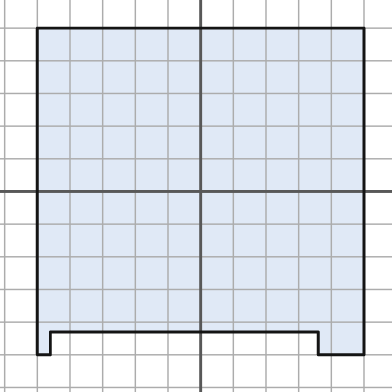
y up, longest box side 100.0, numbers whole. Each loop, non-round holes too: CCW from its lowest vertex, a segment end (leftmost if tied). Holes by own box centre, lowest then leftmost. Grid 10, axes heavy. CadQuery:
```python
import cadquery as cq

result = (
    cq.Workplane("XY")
    .moveTo(-50.0, -50.0)
    .lineTo(-46.0, -50.0)
    .lineTo(-46.0, -43.0)
    .lineTo(36.0, -43.0)
    .lineTo(36.0, -50.0)
    .lineTo(50.0, -50.0)
    .lineTo(50.0, 50.0)
    .lineTo(-50.0, 50.0)
    .close()
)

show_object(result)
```